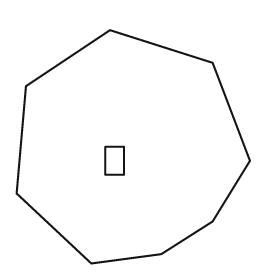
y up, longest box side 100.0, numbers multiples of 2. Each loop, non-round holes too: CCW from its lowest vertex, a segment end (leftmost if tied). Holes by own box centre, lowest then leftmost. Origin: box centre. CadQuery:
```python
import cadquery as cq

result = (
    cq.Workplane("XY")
    .moveTo(-18.0, -50.0)
    .lineTo(12.0, -46.0)
    .lineTo(34.0, -32.0)
    .lineTo(50.0, -6.0)
    .lineTo(34.0, 36.0)
    .lineTo(-10.0, 50.0)
    .lineTo(-46.0, 26.0)
    .lineTo(-50.0, -20.0)
    .close()
    .moveTo(-12.0, -12.0)
    .lineTo(-4.0, -12.0)
    .lineTo(-4.0, 0.0)
    .lineTo(-12.0, 0.0)
    .close()
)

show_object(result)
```